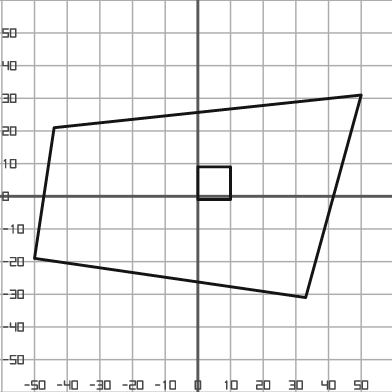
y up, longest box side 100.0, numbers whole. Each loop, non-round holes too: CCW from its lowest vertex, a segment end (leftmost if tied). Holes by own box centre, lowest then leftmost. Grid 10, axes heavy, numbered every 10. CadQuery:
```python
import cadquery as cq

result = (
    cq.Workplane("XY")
    .moveTo(33.0, -31.0)
    .lineTo(50.0, 31.0)
    .lineTo(-44.0, 21.0)
    .lineTo(-50.0, -19.0)
    .close()
    .moveTo(0.0, -1.0)
    .lineTo(10.0, -1.0)
    .lineTo(10.0, 9.0)
    .lineTo(0.0, 9.0)
    .close()
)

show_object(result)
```